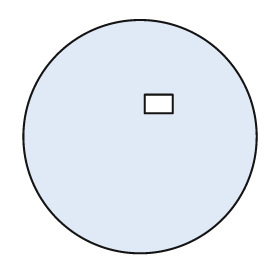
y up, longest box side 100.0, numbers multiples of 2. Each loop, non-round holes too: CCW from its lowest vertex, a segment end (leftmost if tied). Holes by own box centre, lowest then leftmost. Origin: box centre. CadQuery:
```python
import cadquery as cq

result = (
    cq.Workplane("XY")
    .moveTo(0.0, 0.0)
    .circle(50.0)
    .moveTo(2.0, 10.0)
    .lineTo(14.0, 10.0)
    .lineTo(14.0, 18.0)
    .lineTo(2.0, 18.0)
    .close()
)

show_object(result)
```